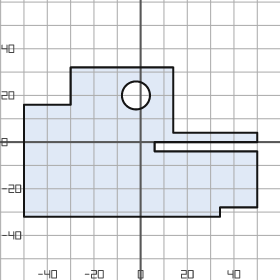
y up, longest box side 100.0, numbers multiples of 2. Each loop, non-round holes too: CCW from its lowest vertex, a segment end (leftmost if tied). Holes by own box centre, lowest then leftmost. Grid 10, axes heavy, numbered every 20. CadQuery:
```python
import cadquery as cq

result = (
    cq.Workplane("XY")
    .moveTo(-50.0, -32.0)
    .lineTo(34.0, -32.0)
    .lineTo(34.0, -28.0)
    .lineTo(50.0, -28.0)
    .lineTo(50.0, -4.0)
    .lineTo(6.0, -4.0)
    .lineTo(6.0, 0.0)
    .lineTo(50.0, 0.0)
    .lineTo(50.0, 4.0)
    .lineTo(14.0, 4.0)
    .lineTo(14.0, 32.0)
    .lineTo(-30.0, 32.0)
    .lineTo(-30.0, 16.0)
    .lineTo(-50.0, 16.0)
    .close()
    .moveTo(-2.0, 20.0)
    .circle(6.0)
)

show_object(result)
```